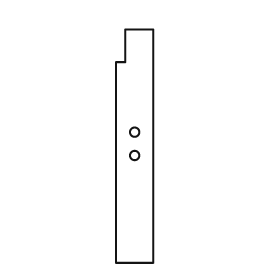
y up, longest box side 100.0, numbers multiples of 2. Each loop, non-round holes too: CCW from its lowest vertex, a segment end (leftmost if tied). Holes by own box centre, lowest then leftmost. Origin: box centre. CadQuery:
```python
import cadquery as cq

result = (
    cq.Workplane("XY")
    .moveTo(-8.0, -50.0)
    .lineTo(8.0, -50.0)
    .lineTo(8.0, 50.0)
    .lineTo(-4.0, 50.0)
    .lineTo(-4.0, 36.0)
    .lineTo(-8.0, 36.0)
    .close()
    .moveTo(0.0, -4.0)
    .circle(2.0)
    .moveTo(0.0, 6.0)
    .circle(2.0)
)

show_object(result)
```